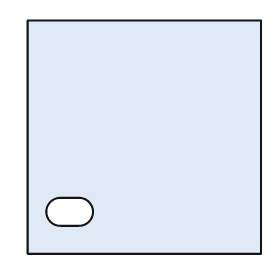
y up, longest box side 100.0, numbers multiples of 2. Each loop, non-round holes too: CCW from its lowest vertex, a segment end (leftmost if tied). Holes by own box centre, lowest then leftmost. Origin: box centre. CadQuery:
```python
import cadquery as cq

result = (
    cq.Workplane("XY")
    .moveTo(-50.0, -50.0)
    .lineTo(50.0, -50.0)
    .lineTo(50.0, 50.0)
    .lineTo(-50.0, 50.0)
    .close()
    .moveTo(-36.0, -38.0)
    .lineTo(-28.0, -38.0)
    .threePointArc((-22.0, -32.0), (-28.0, -26.0))
    .lineTo(-36.0, -26.0)
    .threePointArc((-42.0, -32.0), (-36.0, -38.0))
    .close()
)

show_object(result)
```